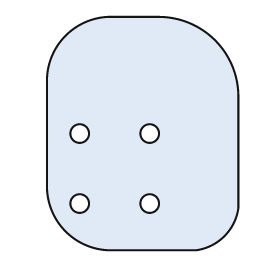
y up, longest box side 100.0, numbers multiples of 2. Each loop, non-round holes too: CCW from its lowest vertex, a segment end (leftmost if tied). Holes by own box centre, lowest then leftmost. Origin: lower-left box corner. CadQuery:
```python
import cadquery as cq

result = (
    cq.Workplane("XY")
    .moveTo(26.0, 0.0)
    .lineTo(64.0, 0.0)
    .threePointArc((76.0, 6.0), (82.0, 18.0))
    .lineTo(82.0, 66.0)
    .threePointArc((72.0, 90.0), (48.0, 100.0))
    .lineTo(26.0, 100.0)
    .threePointArc((8.0, 92.0), (0.0, 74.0))
    .lineTo(0.0, 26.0)
    .threePointArc((8.0, 8.0), (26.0, 0.0))
    .close()
    .moveTo(14.0, 20.0)
    .circle(4.0)
    .moveTo(44.0, 20.0)
    .circle(4.0)
    .moveTo(14.0, 50.0)
    .circle(4.0)
    .moveTo(44.0, 50.0)
    .circle(4.0)
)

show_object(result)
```